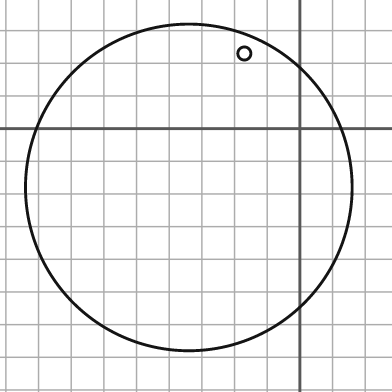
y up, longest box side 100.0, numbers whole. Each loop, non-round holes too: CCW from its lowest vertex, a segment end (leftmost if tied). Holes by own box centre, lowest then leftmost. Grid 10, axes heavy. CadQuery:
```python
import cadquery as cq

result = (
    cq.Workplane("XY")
    .moveTo(-34.0, -18.0)
    .circle(50.0)
    .moveTo(-17.0, 23.0)
    .circle(2.0)
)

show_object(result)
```